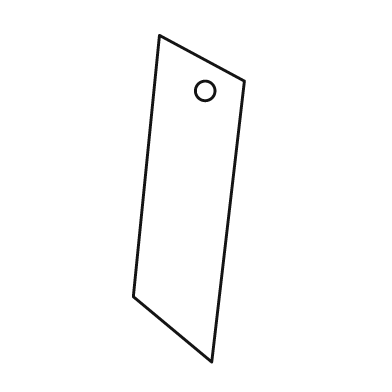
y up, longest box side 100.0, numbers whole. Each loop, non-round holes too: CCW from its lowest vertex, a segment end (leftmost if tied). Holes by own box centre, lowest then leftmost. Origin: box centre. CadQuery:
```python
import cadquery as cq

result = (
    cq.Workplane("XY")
    .moveTo(7.0, -50.0)
    .lineTo(17.0, 36.0)
    .lineTo(-9.0, 50.0)
    .lineTo(-17.0, -30.0)
    .close()
    .moveTo(5.0, 33.0)
    .circle(3.0)
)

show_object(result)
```